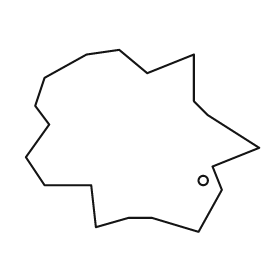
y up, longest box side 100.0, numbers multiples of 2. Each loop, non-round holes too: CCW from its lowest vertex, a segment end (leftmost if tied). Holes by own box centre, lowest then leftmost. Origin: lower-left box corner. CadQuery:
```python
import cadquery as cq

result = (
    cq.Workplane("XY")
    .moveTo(74.0, 0.0)
    .lineTo(84.0, 18.0)
    .lineTo(80.0, 28.0)
    .lineTo(100.0, 36.0)
    .lineTo(78.0, 50.0)
    .lineTo(72.0, 56.0)
    .lineTo(72.0, 76.0)
    .lineTo(52.0, 68.0)
    .lineTo(40.0, 78.0)
    .lineTo(26.0, 76.0)
    .lineTo(8.0, 66.0)
    .lineTo(4.0, 54.0)
    .lineTo(10.0, 46.0)
    .lineTo(0.0, 32.0)
    .lineTo(8.0, 20.0)
    .lineTo(28.0, 20.0)
    .lineTo(30.0, 2.0)
    .lineTo(44.0, 6.0)
    .lineTo(54.0, 6.0)
    .close()
    .moveTo(76.0, 22.0)
    .circle(2.0)
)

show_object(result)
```